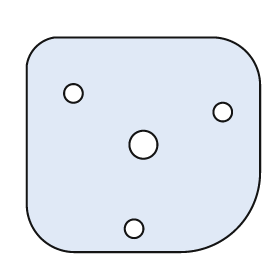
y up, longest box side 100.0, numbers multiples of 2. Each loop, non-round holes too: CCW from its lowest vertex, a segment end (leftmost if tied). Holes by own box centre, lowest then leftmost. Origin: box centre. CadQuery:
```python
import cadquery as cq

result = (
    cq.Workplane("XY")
    .moveTo(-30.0, -46.0)
    .lineTo(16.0, -46.0)
    .threePointArc((40.0, -36.0), (50.0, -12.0))
    .lineTo(50.0, 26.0)
    .threePointArc((44.0, 40.0), (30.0, 46.0))
    .lineTo(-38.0, 46.0)
    .threePointArc((-46.0, 42.0), (-50.0, 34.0))
    .lineTo(-50.0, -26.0)
    .threePointArc((-44.0, -40.0), (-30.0, -46.0))
    .close()
    .moveTo(-4.0, -36.0)
    .circle(4.0)
    .moveTo(0.0, 0.0)
    .circle(6.0)
    .moveTo(34.0, 14.0)
    .circle(4.0)
    .moveTo(-30.0, 22.0)
    .circle(4.0)
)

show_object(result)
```